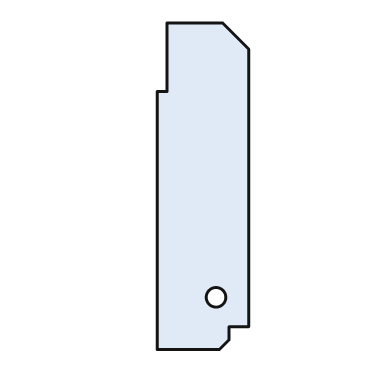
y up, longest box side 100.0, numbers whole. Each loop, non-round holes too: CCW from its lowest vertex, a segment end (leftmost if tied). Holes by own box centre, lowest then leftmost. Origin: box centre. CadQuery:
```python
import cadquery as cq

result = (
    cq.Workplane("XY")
    .moveTo(-14.0, -50.0)
    .lineTo(5.0, -50.0)
    .lineTo(8.0, -47.0)
    .lineTo(8.0, -43.0)
    .lineTo(14.0, -43.0)
    .lineTo(14.0, 42.0)
    .lineTo(6.0, 50.0)
    .lineTo(-11.0, 50.0)
    .lineTo(-11.0, 29.0)
    .lineTo(-14.0, 29.0)
    .close()
    .moveTo(4.0, -34.0)
    .circle(3.0)
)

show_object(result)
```